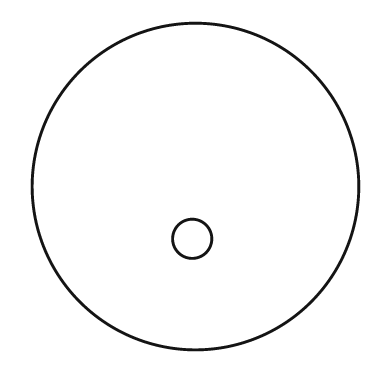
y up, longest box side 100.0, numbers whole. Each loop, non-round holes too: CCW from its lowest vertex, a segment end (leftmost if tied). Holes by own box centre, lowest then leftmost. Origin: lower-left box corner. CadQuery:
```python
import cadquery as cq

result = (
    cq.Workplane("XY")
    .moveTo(50.0, 50.0)
    .circle(50.0)
    .moveTo(49.0, 34.0)
    .circle(6.0)
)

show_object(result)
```